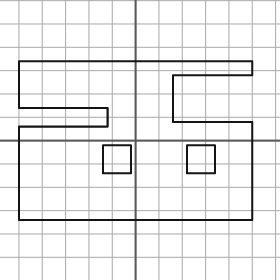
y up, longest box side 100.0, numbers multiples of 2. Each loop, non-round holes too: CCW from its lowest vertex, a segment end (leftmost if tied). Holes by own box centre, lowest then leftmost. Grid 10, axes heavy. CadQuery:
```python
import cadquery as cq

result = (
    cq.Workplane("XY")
    .moveTo(-50.0, -34.0)
    .lineTo(50.0, -34.0)
    .lineTo(50.0, 8.0)
    .lineTo(16.0, 8.0)
    .lineTo(16.0, 28.0)
    .lineTo(50.0, 28.0)
    .lineTo(50.0, 34.0)
    .lineTo(-50.0, 34.0)
    .lineTo(-50.0, 14.0)
    .lineTo(-12.0, 14.0)
    .lineTo(-12.0, 6.0)
    .lineTo(-50.0, 6.0)
    .close()
    .moveTo(-14.0, -14.0)
    .lineTo(-2.0, -14.0)
    .lineTo(-2.0, -2.0)
    .lineTo(-14.0, -2.0)
    .close()
    .moveTo(22.0, -14.0)
    .lineTo(34.0, -14.0)
    .lineTo(34.0, -2.0)
    .lineTo(22.0, -2.0)
    .close()
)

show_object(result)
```